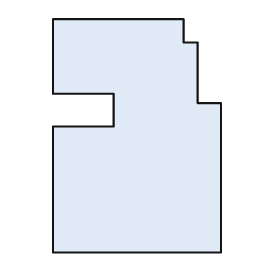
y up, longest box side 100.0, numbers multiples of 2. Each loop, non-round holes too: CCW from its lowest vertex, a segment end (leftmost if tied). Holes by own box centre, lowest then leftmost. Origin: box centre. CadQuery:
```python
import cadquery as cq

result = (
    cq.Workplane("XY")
    .moveTo(-36.0, -50.0)
    .lineTo(36.0, -50.0)
    .lineTo(36.0, 14.0)
    .lineTo(26.0, 14.0)
    .lineTo(26.0, 40.0)
    .lineTo(20.0, 40.0)
    .lineTo(20.0, 50.0)
    .lineTo(-36.0, 50.0)
    .lineTo(-36.0, 18.0)
    .lineTo(-10.0, 18.0)
    .lineTo(-10.0, 4.0)
    .lineTo(-36.0, 4.0)
    .close()
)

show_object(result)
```